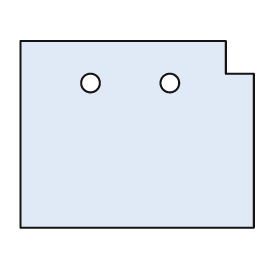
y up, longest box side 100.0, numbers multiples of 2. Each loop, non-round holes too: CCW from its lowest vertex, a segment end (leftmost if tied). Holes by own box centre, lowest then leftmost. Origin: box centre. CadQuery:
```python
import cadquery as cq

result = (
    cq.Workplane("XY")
    .moveTo(-50.0, -40.0)
    .lineTo(50.0, -40.0)
    .lineTo(50.0, 26.0)
    .lineTo(38.0, 26.0)
    .lineTo(38.0, 40.0)
    .lineTo(-50.0, 40.0)
    .close()
    .moveTo(-20.0, 22.0)
    .circle(4.0)
    .moveTo(14.0, 22.0)
    .circle(4.0)
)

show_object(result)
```